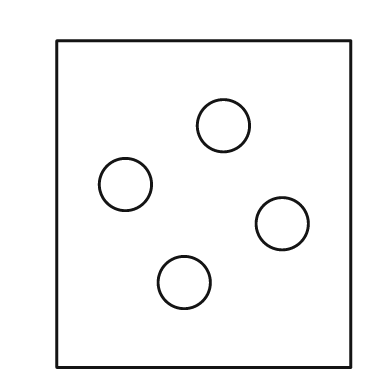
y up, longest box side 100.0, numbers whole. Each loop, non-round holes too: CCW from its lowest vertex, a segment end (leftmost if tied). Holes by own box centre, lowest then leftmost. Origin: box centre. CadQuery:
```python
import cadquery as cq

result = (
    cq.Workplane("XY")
    .moveTo(-45.0, -50.0)
    .lineTo(45.0, -50.0)
    .lineTo(45.0, 50.0)
    .lineTo(-45.0, 50.0)
    .close()
    .moveTo(-6.0, -24.0)
    .circle(8.0)
    .moveTo(24.0, -6.0)
    .circle(8.0)
    .moveTo(-24.0, 6.0)
    .circle(8.0)
    .moveTo(6.0, 24.0)
    .circle(8.0)
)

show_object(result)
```